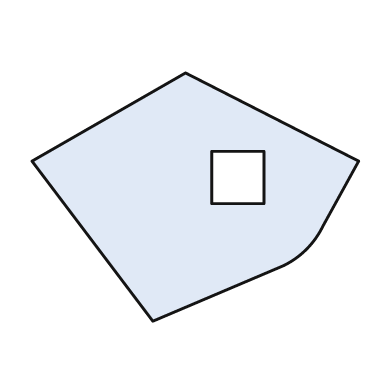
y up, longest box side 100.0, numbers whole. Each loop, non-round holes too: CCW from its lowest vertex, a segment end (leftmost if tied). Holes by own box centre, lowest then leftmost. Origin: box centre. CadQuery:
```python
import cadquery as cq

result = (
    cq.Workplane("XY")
    .moveTo(-13.0, -38.0)
    .lineTo(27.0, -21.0)
    .threePointArc((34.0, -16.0), (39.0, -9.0))
    .lineTo(50.0, 11.0)
    .lineTo(-3.0, 38.0)
    .lineTo(-50.0, 11.0)
    .close()
    .moveTo(5.0, -2.0)
    .lineTo(21.0, -2.0)
    .lineTo(21.0, 14.0)
    .lineTo(5.0, 14.0)
    .close()
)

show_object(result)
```